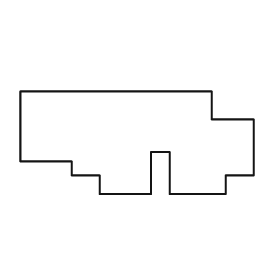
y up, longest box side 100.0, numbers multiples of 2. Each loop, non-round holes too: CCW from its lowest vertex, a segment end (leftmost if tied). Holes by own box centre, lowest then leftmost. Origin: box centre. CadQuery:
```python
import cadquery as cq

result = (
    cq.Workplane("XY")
    .moveTo(-16.0, -22.0)
    .lineTo(6.0, -22.0)
    .lineTo(6.0, -4.0)
    .lineTo(14.0, -4.0)
    .lineTo(14.0, -22.0)
    .lineTo(38.0, -22.0)
    .lineTo(38.0, -14.0)
    .lineTo(50.0, -14.0)
    .lineTo(50.0, 10.0)
    .lineTo(32.0, 10.0)
    .lineTo(32.0, 22.0)
    .lineTo(-50.0, 22.0)
    .lineTo(-50.0, -8.0)
    .lineTo(-28.0, -8.0)
    .lineTo(-28.0, -14.0)
    .lineTo(-16.0, -14.0)
    .close()
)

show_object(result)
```